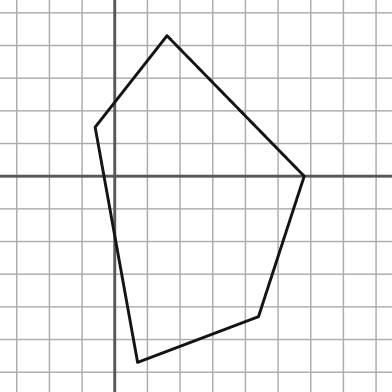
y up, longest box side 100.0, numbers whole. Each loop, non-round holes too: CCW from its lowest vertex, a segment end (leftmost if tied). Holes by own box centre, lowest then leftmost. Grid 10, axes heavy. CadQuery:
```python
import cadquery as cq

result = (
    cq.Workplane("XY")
    .moveTo(7.0, -57.0)
    .lineTo(44.0, -43.0)
    .lineTo(58.0, 0.0)
    .lineTo(16.0, 43.0)
    .lineTo(-6.0, 15.0)
    .close()
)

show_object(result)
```